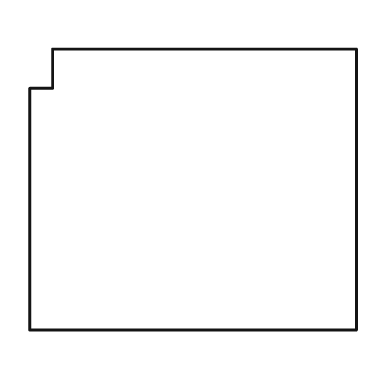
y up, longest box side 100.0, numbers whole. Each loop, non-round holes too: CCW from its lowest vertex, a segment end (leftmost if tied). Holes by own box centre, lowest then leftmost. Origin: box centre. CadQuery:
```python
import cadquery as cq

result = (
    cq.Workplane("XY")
    .moveTo(-50.0, -43.0)
    .lineTo(50.0, -43.0)
    .lineTo(50.0, 43.0)
    .lineTo(-43.0, 43.0)
    .lineTo(-43.0, 31.0)
    .lineTo(-50.0, 31.0)
    .close()
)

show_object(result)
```